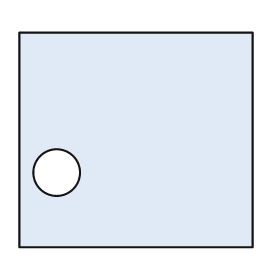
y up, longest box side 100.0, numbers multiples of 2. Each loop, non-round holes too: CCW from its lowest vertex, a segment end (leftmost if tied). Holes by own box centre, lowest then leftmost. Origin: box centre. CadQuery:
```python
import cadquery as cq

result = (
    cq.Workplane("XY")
    .moveTo(-50.0, -46.0)
    .lineTo(50.0, -46.0)
    .lineTo(50.0, 46.0)
    .lineTo(-50.0, 46.0)
    .close()
    .moveTo(-34.0, -14.0)
    .circle(10.0)
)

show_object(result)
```